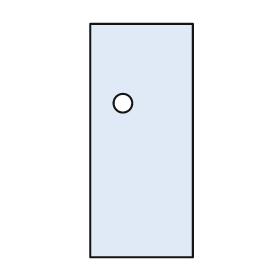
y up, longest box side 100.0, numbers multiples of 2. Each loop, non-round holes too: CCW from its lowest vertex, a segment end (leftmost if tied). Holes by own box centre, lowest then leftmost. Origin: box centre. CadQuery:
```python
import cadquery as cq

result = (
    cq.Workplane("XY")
    .moveTo(-22.0, -50.0)
    .lineTo(22.0, -50.0)
    .lineTo(22.0, 50.0)
    .lineTo(-22.0, 50.0)
    .close()
    .moveTo(-8.0, 16.0)
    .circle(4.0)
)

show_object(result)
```